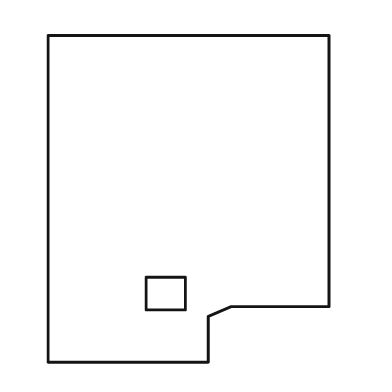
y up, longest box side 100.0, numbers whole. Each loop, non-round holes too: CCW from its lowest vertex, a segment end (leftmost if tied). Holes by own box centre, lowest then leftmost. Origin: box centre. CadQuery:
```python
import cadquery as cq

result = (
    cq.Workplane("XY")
    .moveTo(-43.0, -50.0)
    .lineTo(6.0, -50.0)
    .lineTo(6.0, -36.0)
    .lineTo(13.0, -33.0)
    .lineTo(43.0, -33.0)
    .lineTo(43.0, 50.0)
    .lineTo(-43.0, 50.0)
    .close()
    .moveTo(-13.0, -34.0)
    .lineTo(-1.0, -34.0)
    .lineTo(-1.0, -24.0)
    .lineTo(-13.0, -24.0)
    .close()
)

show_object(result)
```